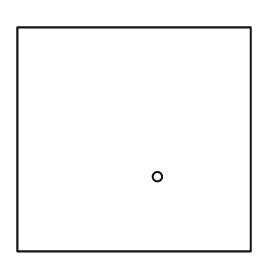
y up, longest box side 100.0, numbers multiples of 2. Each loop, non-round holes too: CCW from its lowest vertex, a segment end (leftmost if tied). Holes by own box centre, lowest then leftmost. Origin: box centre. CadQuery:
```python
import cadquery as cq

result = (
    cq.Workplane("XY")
    .moveTo(-50.0, -48.0)
    .lineTo(50.0, -48.0)
    .lineTo(50.0, 48.0)
    .lineTo(-50.0, 48.0)
    .close()
    .moveTo(10.0, -16.0)
    .circle(2.0)
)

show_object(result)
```